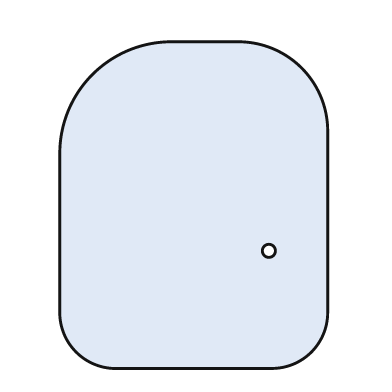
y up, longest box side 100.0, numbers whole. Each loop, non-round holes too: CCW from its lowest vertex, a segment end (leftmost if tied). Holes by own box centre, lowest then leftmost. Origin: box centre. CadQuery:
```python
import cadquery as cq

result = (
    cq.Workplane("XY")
    .moveTo(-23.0, -50.0)
    .lineTo(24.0, -50.0)
    .threePointArc((36.0, -45.0), (41.0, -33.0))
    .lineTo(41.0, 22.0)
    .threePointArc((33.0, 42.0), (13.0, 50.0))
    .lineTo(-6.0, 50.0)
    .threePointArc((-31.0, 40.0), (-41.0, 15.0))
    .lineTo(-41.0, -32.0)
    .threePointArc((-36.0, -45.0), (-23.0, -50.0))
    .close()
    .moveTo(23.0, -14.0)
    .circle(2.0)
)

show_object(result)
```